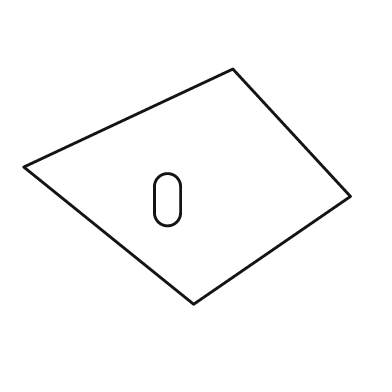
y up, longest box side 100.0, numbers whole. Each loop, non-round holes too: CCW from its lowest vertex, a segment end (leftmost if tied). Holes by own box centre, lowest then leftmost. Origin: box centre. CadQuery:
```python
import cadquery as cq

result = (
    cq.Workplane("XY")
    .moveTo(2.0, -36.0)
    .lineTo(50.0, -3.0)
    .lineTo(14.0, 36.0)
    .lineTo(-50.0, 6.0)
    .close()
    .moveTo(-10.0, -8.0)
    .threePointArc((-6.0, -12.0), (-2.0, -8.0))
    .lineTo(-2.0, 0.0)
    .threePointArc((-6.0, 4.0), (-10.0, 0.0))
    .close()
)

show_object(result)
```